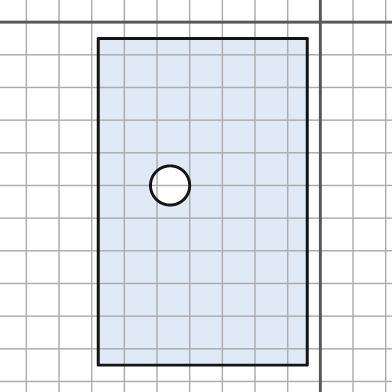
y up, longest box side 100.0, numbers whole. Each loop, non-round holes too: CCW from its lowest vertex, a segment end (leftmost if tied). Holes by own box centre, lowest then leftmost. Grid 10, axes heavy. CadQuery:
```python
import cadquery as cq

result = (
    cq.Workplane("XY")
    .moveTo(-68.0, -105.0)
    .lineTo(-4.0, -105.0)
    .lineTo(-4.0, -5.0)
    .lineTo(-68.0, -5.0)
    .close()
    .moveTo(-46.0, -50.0)
    .circle(6.0)
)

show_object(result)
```